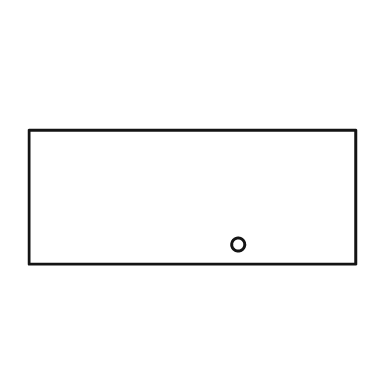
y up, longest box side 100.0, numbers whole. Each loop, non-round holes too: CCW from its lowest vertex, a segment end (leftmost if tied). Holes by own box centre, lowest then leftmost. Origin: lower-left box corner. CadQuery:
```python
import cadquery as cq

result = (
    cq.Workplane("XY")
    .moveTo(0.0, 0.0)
    .lineTo(100.0, 0.0)
    .lineTo(100.0, 41.0)
    .lineTo(0.0, 41.0)
    .close()
    .moveTo(64.0, 6.0)
    .circle(2.0)
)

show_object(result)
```